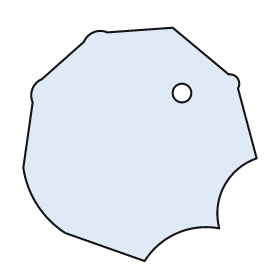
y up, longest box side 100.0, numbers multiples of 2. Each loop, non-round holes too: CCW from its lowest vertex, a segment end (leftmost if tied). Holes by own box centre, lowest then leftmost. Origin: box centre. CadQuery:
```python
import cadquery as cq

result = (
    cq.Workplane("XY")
    .moveTo(2.0, -50.0)
    .threePointArc((16.0, -38.0), (34.0, -36.0))
    .threePointArc((36.0, -18.0), (50.0, -6.0))
    .lineTo(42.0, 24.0)
    .threePointArc((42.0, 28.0), (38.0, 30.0))
    .lineTo(14.0, 50.0)
    .lineTo(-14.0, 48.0)
    .threePointArc((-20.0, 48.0), (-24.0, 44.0))
    .lineTo(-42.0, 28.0)
    .threePointArc((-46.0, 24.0), (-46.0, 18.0))
    .lineTo(-50.0, -10.0)
    .threePointArc((-44.0, -26.0), (-32.0, -38.0))
    .close()
    .moveTo(18.0, 22.0)
    .circle(4.0)
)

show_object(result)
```